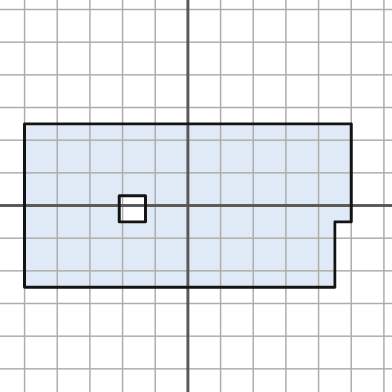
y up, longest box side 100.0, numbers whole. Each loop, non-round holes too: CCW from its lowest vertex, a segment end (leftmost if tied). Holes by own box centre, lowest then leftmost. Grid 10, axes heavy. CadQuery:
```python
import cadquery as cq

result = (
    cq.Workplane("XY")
    .moveTo(-50.0, -25.0)
    .lineTo(45.0, -25.0)
    .lineTo(45.0, -5.0)
    .lineTo(50.0, -5.0)
    .lineTo(50.0, 25.0)
    .lineTo(-50.0, 25.0)
    .close()
    .moveTo(-21.0, -5.0)
    .lineTo(-13.0, -5.0)
    .lineTo(-13.0, 3.0)
    .lineTo(-21.0, 3.0)
    .close()
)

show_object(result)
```